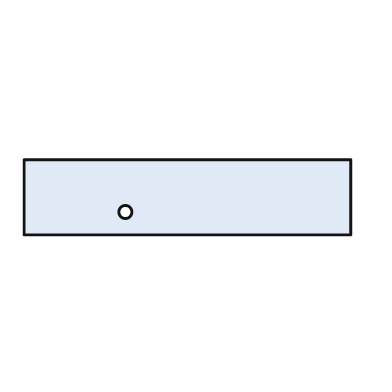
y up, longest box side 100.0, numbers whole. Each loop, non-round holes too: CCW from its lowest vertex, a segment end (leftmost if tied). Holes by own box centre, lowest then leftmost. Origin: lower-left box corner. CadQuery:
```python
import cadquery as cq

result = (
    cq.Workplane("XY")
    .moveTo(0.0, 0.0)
    .lineTo(100.0, 0.0)
    .lineTo(100.0, 23.0)
    .lineTo(0.0, 23.0)
    .close()
    .moveTo(31.0, 7.0)
    .circle(2.0)
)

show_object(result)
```